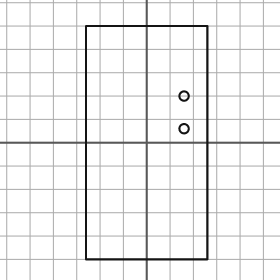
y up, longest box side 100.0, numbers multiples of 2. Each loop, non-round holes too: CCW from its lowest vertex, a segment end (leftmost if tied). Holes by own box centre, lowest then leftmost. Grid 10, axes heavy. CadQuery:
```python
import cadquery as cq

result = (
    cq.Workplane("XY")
    .moveTo(-26.0, -50.0)
    .lineTo(26.0, -50.0)
    .lineTo(26.0, 50.0)
    .lineTo(-26.0, 50.0)
    .close()
    .moveTo(16.0, 6.0)
    .circle(2.0)
    .moveTo(16.0, 20.0)
    .circle(2.0)
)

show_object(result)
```